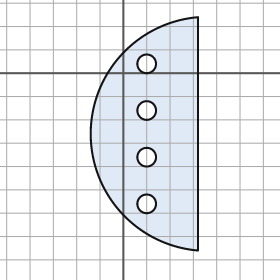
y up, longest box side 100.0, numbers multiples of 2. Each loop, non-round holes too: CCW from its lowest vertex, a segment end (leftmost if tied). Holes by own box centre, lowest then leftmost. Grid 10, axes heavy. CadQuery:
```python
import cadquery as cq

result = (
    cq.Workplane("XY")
    .moveTo(32.0, -76.0)
    .lineTo(32.0, 24.0)
    .threePointArc((-14.0, -26.0), (32.0, -76.0))
    .close()
    .moveTo(10.0, -56.0)
    .circle(4.0)
    .moveTo(10.0, -36.0)
    .circle(4.0)
    .moveTo(10.0, -16.0)
    .circle(4.0)
    .moveTo(10.0, 4.0)
    .circle(4.0)
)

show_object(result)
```